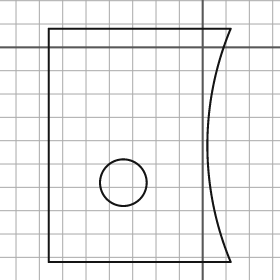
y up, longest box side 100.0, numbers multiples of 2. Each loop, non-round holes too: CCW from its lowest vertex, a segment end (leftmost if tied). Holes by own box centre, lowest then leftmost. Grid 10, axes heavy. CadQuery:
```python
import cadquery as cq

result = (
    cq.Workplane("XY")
    .moveTo(-66.0, -92.0)
    .lineTo(12.0, -92.0)
    .threePointArc((2.0, -42.0), (12.0, 8.0))
    .lineTo(-66.0, 8.0)
    .close()
    .moveTo(-34.0, -58.0)
    .circle(10.0)
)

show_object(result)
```